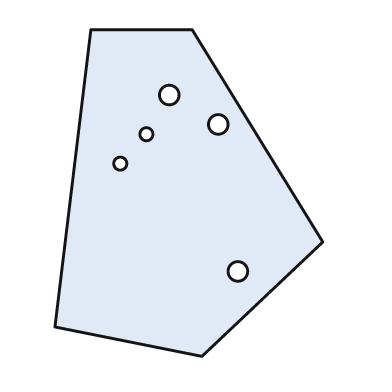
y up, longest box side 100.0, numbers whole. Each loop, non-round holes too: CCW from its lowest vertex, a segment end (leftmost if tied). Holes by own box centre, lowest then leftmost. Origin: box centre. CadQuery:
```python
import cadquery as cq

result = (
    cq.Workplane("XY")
    .moveTo(4.0, -50.0)
    .lineTo(41.0, -15.0)
    .lineTo(1.0, 50.0)
    .lineTo(-30.0, 50.0)
    .lineTo(-41.0, -41.0)
    .close()
    .moveTo(15.0, -24.0)
    .circle(3.0)
    .moveTo(-21.0, 9.0)
    .circle(2.0)
    .moveTo(-13.0, 18.0)
    .circle(2.0)
    .moveTo(9.0, 21.0)
    .circle(3.0)
    .moveTo(-6.0, 30.0)
    .circle(3.0)
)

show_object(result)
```